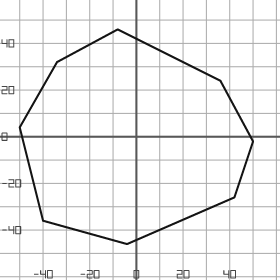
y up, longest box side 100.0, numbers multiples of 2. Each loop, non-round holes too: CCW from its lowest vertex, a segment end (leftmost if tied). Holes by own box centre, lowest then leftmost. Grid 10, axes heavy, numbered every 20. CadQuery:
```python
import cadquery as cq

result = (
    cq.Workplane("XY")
    .moveTo(-4.0, -46.0)
    .lineTo(42.0, -26.0)
    .lineTo(50.0, -2.0)
    .lineTo(36.0, 24.0)
    .lineTo(-8.0, 46.0)
    .lineTo(-34.0, 32.0)
    .lineTo(-50.0, 4.0)
    .lineTo(-40.0, -36.0)
    .close()
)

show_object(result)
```